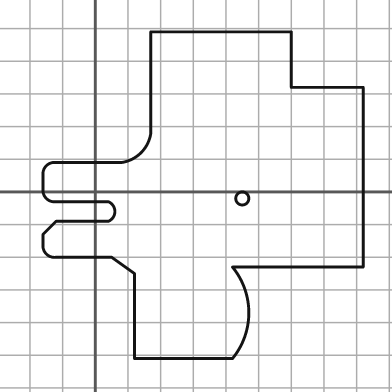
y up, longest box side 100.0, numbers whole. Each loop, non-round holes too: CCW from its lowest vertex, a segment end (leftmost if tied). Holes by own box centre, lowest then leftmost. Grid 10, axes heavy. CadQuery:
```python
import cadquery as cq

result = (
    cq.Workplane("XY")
    .moveTo(12.0, -51.0)
    .lineTo(42.0, -51.0)
    .threePointArc((47.0, -37.0), (42.0, -23.0))
    .lineTo(82.0, -23.0)
    .lineTo(82.0, 32.0)
    .lineTo(60.0, 32.0)
    .lineTo(60.0, 49.0)
    .lineTo(17.0, 49.0)
    .lineTo(17.0, 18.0)
    .threePointArc((14.0, 12.0), (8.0, 9.0))
    .lineTo(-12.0, 9.0)
    .threePointArc((-15.0, 8.0), (-16.0, 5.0))
    .lineTo(-16.0, 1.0)
    .threePointArc((-15.0, -2.0), (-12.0, -3.0))
    .lineTo(4.0, -3.0)
    .threePointArc((6.0, -6.0), (4.0, -9.0))
    .lineTo(-12.0, -9.0)
    .lineTo(-16.0, -13.0)
    .lineTo(-16.0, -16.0)
    .threePointArc((-15.0, -19.0), (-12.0, -20.0))
    .lineTo(5.0, -20.0)
    .lineTo(12.0, -25.0)
    .close()
    .moveTo(45.0, -2.0)
    .circle(2.0)
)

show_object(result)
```